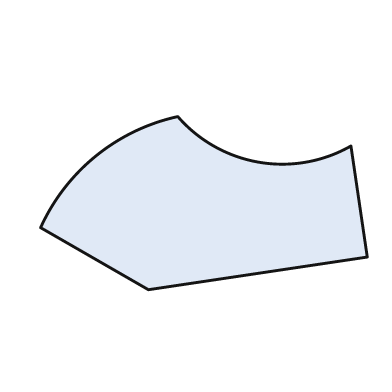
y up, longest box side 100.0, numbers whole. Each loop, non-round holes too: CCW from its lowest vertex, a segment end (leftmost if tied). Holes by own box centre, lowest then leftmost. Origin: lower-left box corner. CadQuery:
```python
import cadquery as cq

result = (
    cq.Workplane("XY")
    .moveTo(33.0, 0.0)
    .lineTo(100.0, 10.0)
    .lineTo(95.0, 44.0)
    .threePointArc((67.0, 39.0), (42.0, 53.0))
    .threePointArc((17.0, 41.0), (0.0, 19.0))
    .close()
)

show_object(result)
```